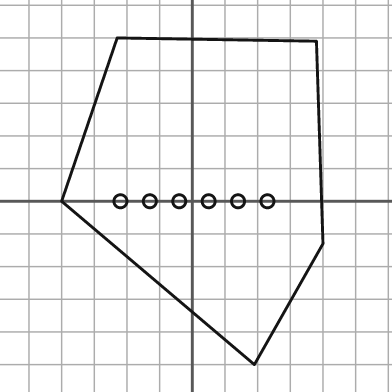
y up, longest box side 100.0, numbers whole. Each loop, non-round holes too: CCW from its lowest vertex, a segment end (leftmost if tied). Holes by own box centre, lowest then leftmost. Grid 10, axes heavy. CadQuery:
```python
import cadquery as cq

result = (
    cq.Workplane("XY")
    .moveTo(19.0, -50.0)
    .lineTo(40.0, -13.0)
    .lineTo(38.0, 49.0)
    .lineTo(-23.0, 50.0)
    .lineTo(-40.0, 0.0)
    .close()
    .moveTo(-22.0, 0.0)
    .circle(2.0)
    .moveTo(-13.0, 0.0)
    .circle(2.0)
    .moveTo(-4.0, 0.0)
    .circle(2.0)
    .moveTo(5.0, 0.0)
    .circle(2.0)
    .moveTo(14.0, 0.0)
    .circle(2.0)
    .moveTo(23.0, 0.0)
    .circle(2.0)
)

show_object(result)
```